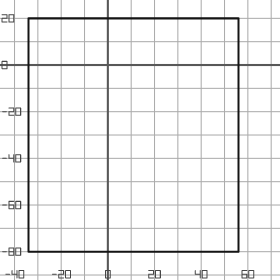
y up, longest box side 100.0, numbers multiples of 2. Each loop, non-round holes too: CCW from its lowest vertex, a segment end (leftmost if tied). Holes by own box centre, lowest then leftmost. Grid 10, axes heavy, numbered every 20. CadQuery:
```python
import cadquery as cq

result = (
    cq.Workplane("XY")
    .moveTo(-34.0, -80.0)
    .lineTo(56.0, -80.0)
    .lineTo(56.0, 20.0)
    .lineTo(-34.0, 20.0)
    .close()
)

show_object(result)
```